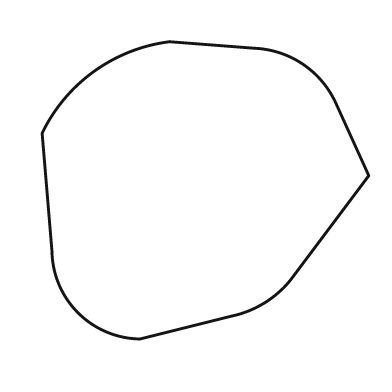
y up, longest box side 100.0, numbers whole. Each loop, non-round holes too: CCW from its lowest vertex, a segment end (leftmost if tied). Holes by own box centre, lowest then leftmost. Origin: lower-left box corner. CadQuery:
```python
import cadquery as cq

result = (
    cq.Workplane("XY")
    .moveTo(30.0, 0.0)
    .lineTo(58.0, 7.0)
    .threePointArc((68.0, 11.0), (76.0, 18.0))
    .lineTo(100.0, 50.0)
    .lineTo(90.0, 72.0)
    .threePointArc((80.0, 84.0), (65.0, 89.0))
    .lineTo(39.0, 91.0)
    .threePointArc((16.0, 82.0), (0.0, 63.0))
    .lineTo(3.0, 27.0)
    .threePointArc((11.0, 8.0), (30.0, 0.0))
    .close()
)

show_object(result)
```